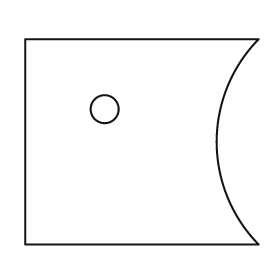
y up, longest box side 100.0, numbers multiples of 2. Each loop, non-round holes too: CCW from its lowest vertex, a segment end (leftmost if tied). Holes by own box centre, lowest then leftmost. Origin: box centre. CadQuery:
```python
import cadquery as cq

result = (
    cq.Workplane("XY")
    .moveTo(-50.0, -44.0)
    .lineTo(50.0, -44.0)
    .threePointArc((32.0, 0.0), (50.0, 44.0))
    .lineTo(-50.0, 44.0)
    .close()
    .moveTo(-16.0, 14.0)
    .circle(6.0)
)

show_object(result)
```